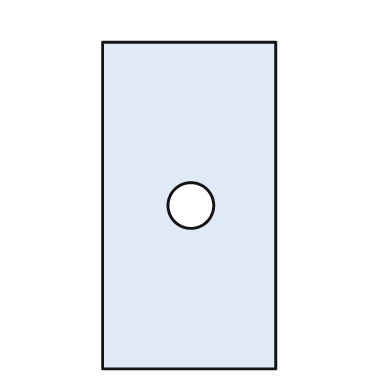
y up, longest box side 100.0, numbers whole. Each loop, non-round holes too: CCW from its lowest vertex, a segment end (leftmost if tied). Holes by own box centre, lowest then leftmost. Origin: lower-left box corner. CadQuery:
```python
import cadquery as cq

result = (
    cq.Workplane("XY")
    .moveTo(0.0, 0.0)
    .lineTo(53.0, 0.0)
    .lineTo(53.0, 100.0)
    .lineTo(0.0, 100.0)
    .close()
    .moveTo(27.0, 50.0)
    .circle(7.0)
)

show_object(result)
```